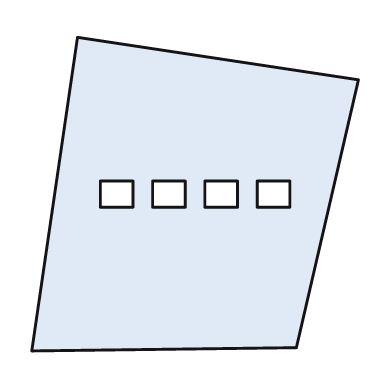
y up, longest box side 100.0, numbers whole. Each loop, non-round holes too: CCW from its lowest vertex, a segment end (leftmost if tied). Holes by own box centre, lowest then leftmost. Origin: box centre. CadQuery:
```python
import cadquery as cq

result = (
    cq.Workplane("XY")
    .moveTo(-50.0, -48.0)
    .lineTo(31.0, -47.0)
    .lineTo(50.0, 35.0)
    .lineTo(-36.0, 48.0)
    .close()
    .moveTo(-29.0, -4.0)
    .lineTo(-19.0, -4.0)
    .lineTo(-19.0, 4.0)
    .lineTo(-29.0, 4.0)
    .close()
    .moveTo(-13.0, -4.0)
    .lineTo(-3.0, -4.0)
    .lineTo(-3.0, 4.0)
    .lineTo(-13.0, 4.0)
    .close()
    .moveTo(3.0, -4.0)
    .lineTo(13.0, -4.0)
    .lineTo(13.0, 4.0)
    .lineTo(3.0, 4.0)
    .close()
    .moveTo(19.0, -4.0)
    .lineTo(29.0, -4.0)
    .lineTo(29.0, 4.0)
    .lineTo(19.0, 4.0)
    .close()
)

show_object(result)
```